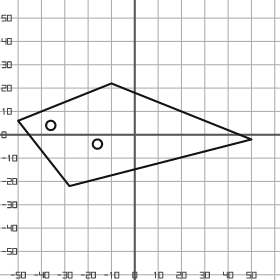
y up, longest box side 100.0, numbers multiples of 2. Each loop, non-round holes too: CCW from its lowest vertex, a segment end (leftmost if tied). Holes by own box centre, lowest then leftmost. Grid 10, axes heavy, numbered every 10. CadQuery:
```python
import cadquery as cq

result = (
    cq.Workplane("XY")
    .moveTo(-28.0, -22.0)
    .lineTo(50.0, -2.0)
    .lineTo(-10.0, 22.0)
    .lineTo(-50.0, 6.0)
    .close()
    .moveTo(-16.0, -4.0)
    .circle(2.0)
    .moveTo(-36.0, 4.0)
    .circle(2.0)
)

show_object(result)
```